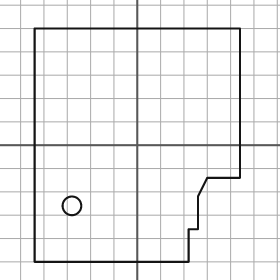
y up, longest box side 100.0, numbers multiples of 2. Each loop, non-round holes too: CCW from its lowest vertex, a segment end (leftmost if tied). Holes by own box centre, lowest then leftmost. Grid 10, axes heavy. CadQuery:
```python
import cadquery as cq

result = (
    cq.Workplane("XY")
    .moveTo(-44.0, -50.0)
    .lineTo(22.0, -50.0)
    .lineTo(22.0, -36.0)
    .lineTo(26.0, -36.0)
    .lineTo(26.0, -22.0)
    .lineTo(30.0, -14.0)
    .lineTo(44.0, -14.0)
    .lineTo(44.0, 50.0)
    .lineTo(-44.0, 50.0)
    .close()
    .moveTo(-28.0, -26.0)
    .circle(4.0)
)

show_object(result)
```